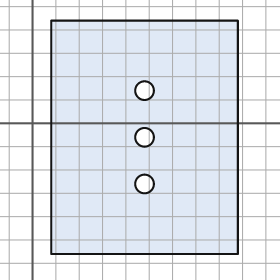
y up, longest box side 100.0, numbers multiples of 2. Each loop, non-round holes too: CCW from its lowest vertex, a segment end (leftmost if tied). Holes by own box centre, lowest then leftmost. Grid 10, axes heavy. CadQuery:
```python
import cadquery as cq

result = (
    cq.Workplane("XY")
    .moveTo(8.0, -56.0)
    .lineTo(88.0, -56.0)
    .lineTo(88.0, 44.0)
    .lineTo(8.0, 44.0)
    .close()
    .moveTo(48.0, -26.0)
    .circle(4.0)
    .moveTo(48.0, -6.0)
    .circle(4.0)
    .moveTo(48.0, 14.0)
    .circle(4.0)
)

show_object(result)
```